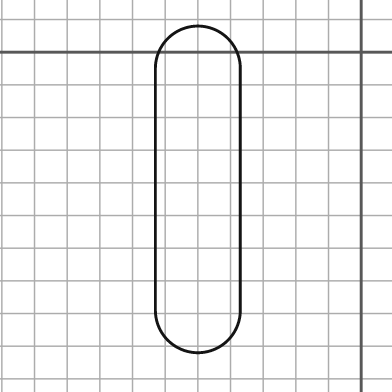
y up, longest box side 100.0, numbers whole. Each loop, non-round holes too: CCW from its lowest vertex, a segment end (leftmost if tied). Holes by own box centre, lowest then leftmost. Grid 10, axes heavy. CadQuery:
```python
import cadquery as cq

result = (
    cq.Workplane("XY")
    .moveTo(-63.0, -79.0)
    .threePointArc((-50.0, -92.0), (-37.0, -79.0))
    .lineTo(-37.0, -5.0)
    .threePointArc((-50.0, 8.0), (-63.0, -5.0))
    .close()
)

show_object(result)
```